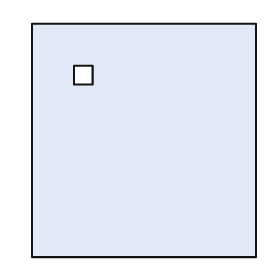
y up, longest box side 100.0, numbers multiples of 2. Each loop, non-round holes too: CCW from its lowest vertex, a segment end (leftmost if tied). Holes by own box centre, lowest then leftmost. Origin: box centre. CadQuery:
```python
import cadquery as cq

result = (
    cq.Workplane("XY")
    .moveTo(-48.0, -50.0)
    .lineTo(48.0, -50.0)
    .lineTo(48.0, 50.0)
    .lineTo(-48.0, 50.0)
    .close()
    .moveTo(-30.0, 24.0)
    .lineTo(-22.0, 24.0)
    .lineTo(-22.0, 32.0)
    .lineTo(-30.0, 32.0)
    .close()
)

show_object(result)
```